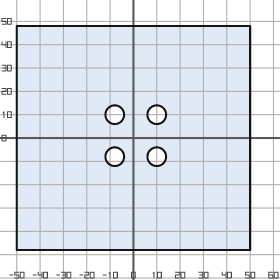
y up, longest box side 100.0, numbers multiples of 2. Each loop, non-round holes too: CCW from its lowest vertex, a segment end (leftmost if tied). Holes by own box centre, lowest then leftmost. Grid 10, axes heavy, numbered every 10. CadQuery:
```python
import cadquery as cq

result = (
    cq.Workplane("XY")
    .moveTo(-50.0, -48.0)
    .lineTo(50.0, -48.0)
    .lineTo(50.0, 48.0)
    .lineTo(-50.0, 48.0)
    .close()
    .moveTo(-8.0, -8.0)
    .circle(4.0)
    .moveTo(10.0, -8.0)
    .circle(4.0)
    .moveTo(-8.0, 10.0)
    .circle(4.0)
    .moveTo(10.0, 10.0)
    .circle(4.0)
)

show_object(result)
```